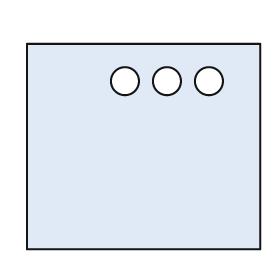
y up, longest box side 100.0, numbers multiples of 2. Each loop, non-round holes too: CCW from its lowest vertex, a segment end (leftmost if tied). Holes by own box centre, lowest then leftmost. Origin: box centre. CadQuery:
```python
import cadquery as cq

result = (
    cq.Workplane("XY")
    .moveTo(-50.0, -44.0)
    .lineTo(50.0, -44.0)
    .lineTo(50.0, 44.0)
    .lineTo(-50.0, 44.0)
    .close()
    .moveTo(-8.0, 28.0)
    .circle(6.0)
    .moveTo(10.0, 28.0)
    .circle(6.0)
    .moveTo(28.0, 28.0)
    .circle(6.0)
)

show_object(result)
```